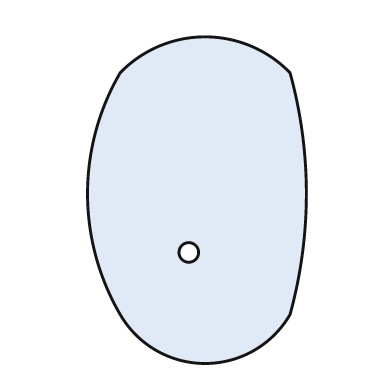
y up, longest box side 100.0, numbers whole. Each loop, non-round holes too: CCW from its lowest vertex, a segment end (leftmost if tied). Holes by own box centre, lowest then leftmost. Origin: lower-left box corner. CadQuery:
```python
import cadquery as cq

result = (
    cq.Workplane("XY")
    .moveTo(10.0, 15.0)
    .threePointArc((36.0, 0.0), (62.0, 15.0))
    .threePointArc((67.0, 52.0), (62.0, 89.0))
    .threePointArc((36.0, 100.0), (10.0, 89.0))
    .threePointArc((0.0, 52.0), (10.0, 15.0))
    .close()
    .moveTo(31.0, 34.0)
    .circle(3.0)
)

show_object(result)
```